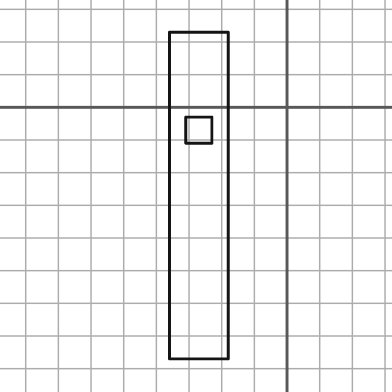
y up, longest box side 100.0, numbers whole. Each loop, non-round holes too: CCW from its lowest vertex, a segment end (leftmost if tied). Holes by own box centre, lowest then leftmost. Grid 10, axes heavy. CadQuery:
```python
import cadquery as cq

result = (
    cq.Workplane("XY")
    .moveTo(-36.0, -77.0)
    .lineTo(-18.0, -77.0)
    .lineTo(-18.0, 23.0)
    .lineTo(-36.0, 23.0)
    .close()
    .moveTo(-31.0, -11.0)
    .lineTo(-23.0, -11.0)
    .lineTo(-23.0, -3.0)
    .lineTo(-31.0, -3.0)
    .close()
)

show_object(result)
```